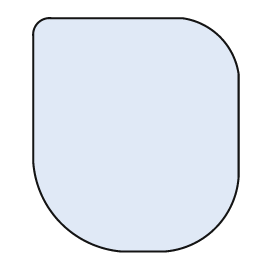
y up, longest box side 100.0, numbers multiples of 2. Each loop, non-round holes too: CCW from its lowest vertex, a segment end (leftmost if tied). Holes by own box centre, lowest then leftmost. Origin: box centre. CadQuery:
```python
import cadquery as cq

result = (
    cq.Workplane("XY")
    .moveTo(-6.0, -50.0)
    .lineTo(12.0, -50.0)
    .threePointArc((34.0, -40.0), (44.0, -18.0))
    .lineTo(44.0, 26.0)
    .threePointArc((36.0, 42.0), (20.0, 50.0))
    .lineTo(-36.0, 50.0)
    .threePointArc((-42.0, 48.0), (-44.0, 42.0))
    .lineTo(-44.0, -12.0)
    .threePointArc((-32.0, -38.0), (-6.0, -50.0))
    .close()
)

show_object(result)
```